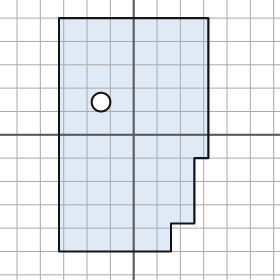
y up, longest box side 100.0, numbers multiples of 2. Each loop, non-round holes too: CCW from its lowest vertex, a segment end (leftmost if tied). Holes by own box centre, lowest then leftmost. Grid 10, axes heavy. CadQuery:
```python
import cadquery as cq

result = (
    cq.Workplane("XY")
    .moveTo(-32.0, -50.0)
    .lineTo(16.0, -50.0)
    .lineTo(16.0, -38.0)
    .lineTo(26.0, -38.0)
    .lineTo(26.0, -10.0)
    .lineTo(32.0, -10.0)
    .lineTo(32.0, 50.0)
    .lineTo(-32.0, 50.0)
    .close()
    .moveTo(-14.0, 14.0)
    .circle(4.0)
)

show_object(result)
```